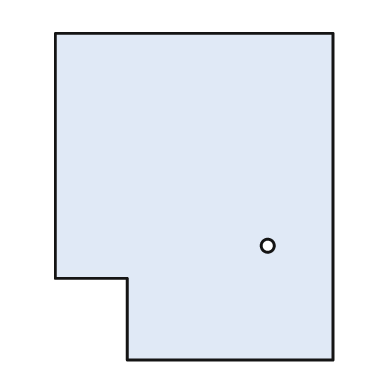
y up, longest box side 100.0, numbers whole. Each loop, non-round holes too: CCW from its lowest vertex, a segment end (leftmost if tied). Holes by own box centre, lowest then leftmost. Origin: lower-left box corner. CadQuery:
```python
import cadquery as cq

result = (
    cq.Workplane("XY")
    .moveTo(22.0, 0.0)
    .lineTo(85.0, 0.0)
    .lineTo(85.0, 100.0)
    .lineTo(0.0, 100.0)
    .lineTo(0.0, 25.0)
    .lineTo(22.0, 25.0)
    .close()
    .moveTo(65.0, 35.0)
    .circle(2.0)
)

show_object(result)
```